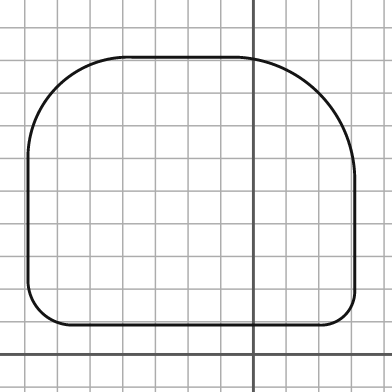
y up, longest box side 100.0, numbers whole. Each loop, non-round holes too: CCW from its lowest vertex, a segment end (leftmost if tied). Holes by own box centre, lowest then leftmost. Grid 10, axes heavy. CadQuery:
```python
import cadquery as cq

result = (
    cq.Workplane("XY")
    .moveTo(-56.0, 9.0)
    .lineTo(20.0, 9.0)
    .threePointArc((28.0, 12.0), (31.0, 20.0))
    .lineTo(31.0, 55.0)
    .threePointArc((20.0, 80.0), (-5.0, 91.0))
    .lineTo(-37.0, 91.0)
    .threePointArc((-60.0, 82.0), (-69.0, 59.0))
    .lineTo(-69.0, 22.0)
    .threePointArc((-65.0, 13.0), (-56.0, 9.0))
    .close()
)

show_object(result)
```